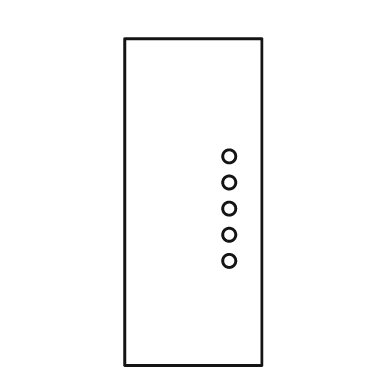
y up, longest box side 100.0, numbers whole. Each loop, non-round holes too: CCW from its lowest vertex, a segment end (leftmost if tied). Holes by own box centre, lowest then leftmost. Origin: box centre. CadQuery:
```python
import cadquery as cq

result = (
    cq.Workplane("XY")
    .moveTo(-21.0, -50.0)
    .lineTo(21.0, -50.0)
    .lineTo(21.0, 50.0)
    .lineTo(-21.0, 50.0)
    .close()
    .moveTo(11.0, -18.0)
    .circle(2.0)
    .moveTo(11.0, -10.0)
    .circle(2.0)
    .moveTo(11.0, -2.0)
    .circle(2.0)
    .moveTo(11.0, 6.0)
    .circle(2.0)
    .moveTo(11.0, 14.0)
    .circle(2.0)
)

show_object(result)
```